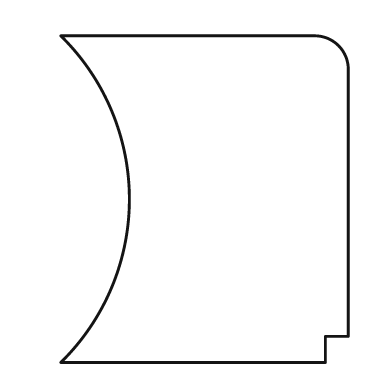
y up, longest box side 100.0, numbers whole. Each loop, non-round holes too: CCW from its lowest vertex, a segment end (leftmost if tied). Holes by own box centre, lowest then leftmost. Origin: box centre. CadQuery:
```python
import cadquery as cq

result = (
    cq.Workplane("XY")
    .moveTo(-44.0, -50.0)
    .lineTo(37.0, -50.0)
    .lineTo(37.0, -42.0)
    .lineTo(44.0, -42.0)
    .lineTo(44.0, 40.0)
    .threePointArc((41.0, 47.0), (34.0, 50.0))
    .lineTo(-44.0, 50.0)
    .threePointArc((-23.0, 0.0), (-44.0, -50.0))
    .close()
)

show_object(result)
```